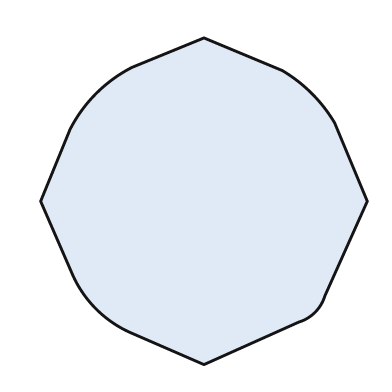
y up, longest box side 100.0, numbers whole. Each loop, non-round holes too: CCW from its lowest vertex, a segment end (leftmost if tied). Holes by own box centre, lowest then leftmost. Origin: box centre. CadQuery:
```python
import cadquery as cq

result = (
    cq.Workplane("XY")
    .moveTo(0.0, -50.0)
    .lineTo(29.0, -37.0)
    .threePointArc((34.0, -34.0), (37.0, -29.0))
    .lineTo(50.0, 0.0)
    .lineTo(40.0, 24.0)
    .threePointArc((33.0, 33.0), (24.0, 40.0))
    .lineTo(0.0, 50.0)
    .lineTo(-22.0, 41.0)
    .threePointArc((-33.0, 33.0), (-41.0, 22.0))
    .lineTo(-50.0, 0.0)
    .lineTo(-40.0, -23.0)
    .threePointArc((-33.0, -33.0), (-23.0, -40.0))
    .close()
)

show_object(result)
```